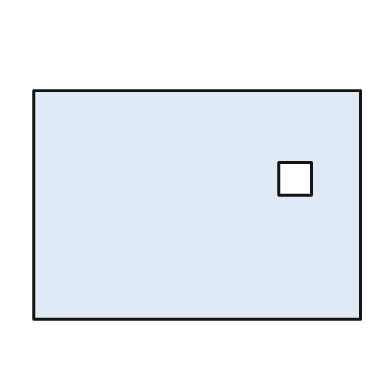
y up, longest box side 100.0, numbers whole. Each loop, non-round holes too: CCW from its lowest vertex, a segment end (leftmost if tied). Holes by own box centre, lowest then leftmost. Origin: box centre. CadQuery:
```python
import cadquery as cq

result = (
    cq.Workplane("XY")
    .moveTo(-50.0, -35.0)
    .lineTo(50.0, -35.0)
    .lineTo(50.0, 35.0)
    .lineTo(-50.0, 35.0)
    .close()
    .moveTo(25.0, 3.0)
    .lineTo(35.0, 3.0)
    .lineTo(35.0, 13.0)
    .lineTo(25.0, 13.0)
    .close()
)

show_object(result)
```